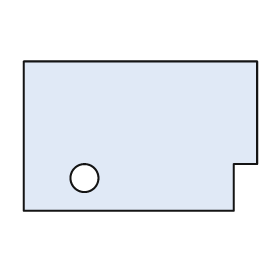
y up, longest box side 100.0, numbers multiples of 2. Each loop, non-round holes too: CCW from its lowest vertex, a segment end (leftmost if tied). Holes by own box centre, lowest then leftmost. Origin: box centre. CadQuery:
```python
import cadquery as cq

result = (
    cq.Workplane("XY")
    .moveTo(-50.0, -32.0)
    .lineTo(40.0, -32.0)
    .lineTo(40.0, -12.0)
    .lineTo(50.0, -12.0)
    .lineTo(50.0, 32.0)
    .lineTo(-50.0, 32.0)
    .close()
    .moveTo(-24.0, -18.0)
    .circle(6.0)
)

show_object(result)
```